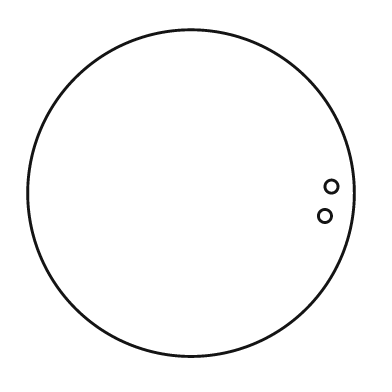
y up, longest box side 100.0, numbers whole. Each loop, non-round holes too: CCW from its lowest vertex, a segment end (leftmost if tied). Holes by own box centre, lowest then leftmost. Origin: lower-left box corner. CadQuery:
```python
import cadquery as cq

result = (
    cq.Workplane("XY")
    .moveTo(50.0, 50.0)
    .circle(50.0)
    .moveTo(91.0, 43.0)
    .circle(2.0)
    .moveTo(93.0, 52.0)
    .circle(2.0)
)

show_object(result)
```